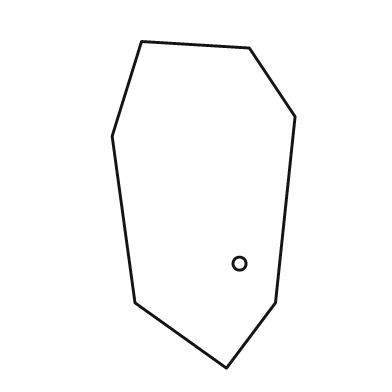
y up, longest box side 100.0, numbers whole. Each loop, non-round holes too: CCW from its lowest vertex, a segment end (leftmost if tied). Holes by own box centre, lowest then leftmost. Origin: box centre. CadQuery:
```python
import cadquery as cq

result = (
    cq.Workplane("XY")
    .moveTo(7.0, -50.0)
    .lineTo(22.0, -30.0)
    .lineTo(28.0, 27.0)
    .lineTo(14.0, 48.0)
    .lineTo(-19.0, 50.0)
    .lineTo(-28.0, 21.0)
    .lineTo(-21.0, -30.0)
    .close()
    .moveTo(11.0, -18.0)
    .circle(2.0)
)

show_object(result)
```